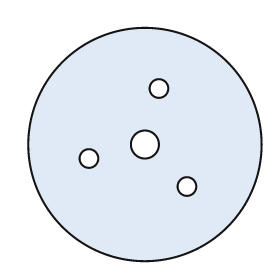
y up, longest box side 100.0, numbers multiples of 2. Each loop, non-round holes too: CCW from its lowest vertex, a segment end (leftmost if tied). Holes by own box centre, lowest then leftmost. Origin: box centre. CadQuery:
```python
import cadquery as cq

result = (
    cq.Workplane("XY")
    .moveTo(0.0, 0.0)
    .circle(50.0)
    .moveTo(18.0, -18.0)
    .circle(4.0)
    .moveTo(-24.0, -6.0)
    .circle(4.0)
    .moveTo(0.0, 0.0)
    .circle(6.0)
    .moveTo(6.0, 24.0)
    .circle(4.0)
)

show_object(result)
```